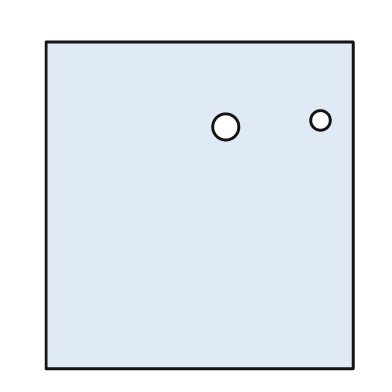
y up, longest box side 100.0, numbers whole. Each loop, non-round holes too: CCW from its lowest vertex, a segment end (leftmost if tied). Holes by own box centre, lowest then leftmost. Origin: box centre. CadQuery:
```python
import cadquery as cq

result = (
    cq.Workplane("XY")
    .moveTo(-47.0, -50.0)
    .lineTo(47.0, -50.0)
    .lineTo(47.0, 50.0)
    .lineTo(-47.0, 50.0)
    .close()
    .moveTo(8.0, 24.0)
    .circle(4.0)
    .moveTo(37.0, 26.0)
    .circle(3.0)
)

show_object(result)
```